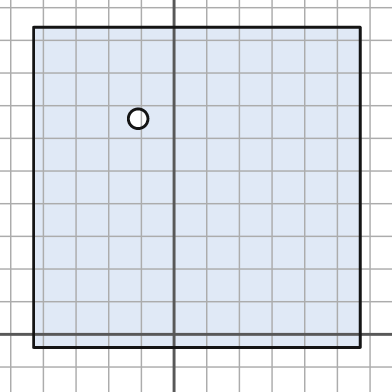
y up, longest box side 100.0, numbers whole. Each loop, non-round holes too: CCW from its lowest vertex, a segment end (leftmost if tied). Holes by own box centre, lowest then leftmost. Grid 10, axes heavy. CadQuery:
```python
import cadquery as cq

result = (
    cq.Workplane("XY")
    .moveTo(-43.0, -4.0)
    .lineTo(57.0, -4.0)
    .lineTo(57.0, 94.0)
    .lineTo(-43.0, 94.0)
    .close()
    .moveTo(-11.0, 66.0)
    .circle(3.0)
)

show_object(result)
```